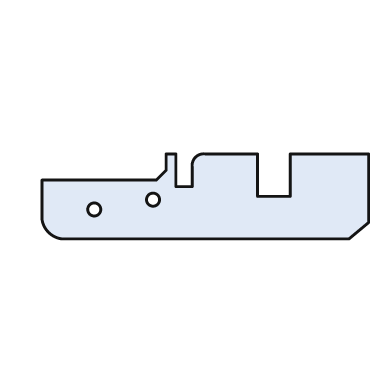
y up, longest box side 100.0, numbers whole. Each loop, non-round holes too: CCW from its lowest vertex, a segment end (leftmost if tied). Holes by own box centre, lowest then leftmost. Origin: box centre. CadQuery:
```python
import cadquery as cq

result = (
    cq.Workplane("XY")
    .moveTo(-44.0, -13.0)
    .lineTo(44.0, -13.0)
    .lineTo(50.0, -8.0)
    .lineTo(50.0, 13.0)
    .lineTo(26.0, 13.0)
    .lineTo(26.0, 0.0)
    .lineTo(16.0, 0.0)
    .lineTo(16.0, 13.0)
    .lineTo(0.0, 13.0)
    .threePointArc((-3.0, 12.0), (-4.0, 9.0))
    .lineTo(-4.0, 3.0)
    .lineTo(-9.0, 3.0)
    .lineTo(-9.0, 13.0)
    .lineTo(-12.0, 13.0)
    .lineTo(-12.0, 8.0)
    .lineTo(-15.0, 5.0)
    .lineTo(-50.0, 5.0)
    .lineTo(-50.0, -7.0)
    .threePointArc((-48.0, -11.0), (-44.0, -13.0))
    .close()
    .moveTo(-34.0, -4.0)
    .circle(2.0)
    .moveTo(-16.0, -1.0)
    .circle(2.0)
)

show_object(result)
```